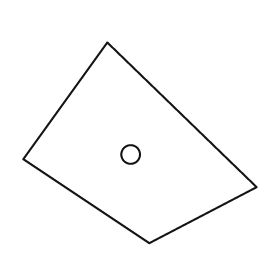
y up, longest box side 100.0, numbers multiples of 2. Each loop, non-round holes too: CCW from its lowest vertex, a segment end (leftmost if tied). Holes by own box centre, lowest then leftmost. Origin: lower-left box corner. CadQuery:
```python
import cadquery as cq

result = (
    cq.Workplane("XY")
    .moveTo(54.0, 0.0)
    .lineTo(100.0, 24.0)
    .lineTo(36.0, 86.0)
    .lineTo(0.0, 36.0)
    .close()
    .moveTo(46.0, 38.0)
    .circle(4.0)
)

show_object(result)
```